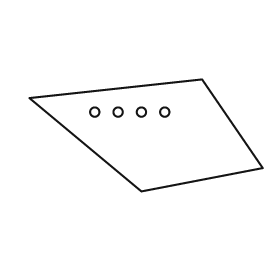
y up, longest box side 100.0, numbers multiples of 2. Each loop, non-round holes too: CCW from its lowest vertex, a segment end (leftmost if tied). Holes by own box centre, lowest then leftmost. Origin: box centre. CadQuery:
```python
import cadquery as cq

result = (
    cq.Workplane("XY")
    .moveTo(-2.0, -24.0)
    .lineTo(50.0, -14.0)
    .lineTo(24.0, 24.0)
    .lineTo(-50.0, 16.0)
    .close()
    .moveTo(-22.0, 10.0)
    .circle(2.0)
    .moveTo(-12.0, 10.0)
    .circle(2.0)
    .moveTo(-2.0, 10.0)
    .circle(2.0)
    .moveTo(8.0, 10.0)
    .circle(2.0)
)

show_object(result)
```